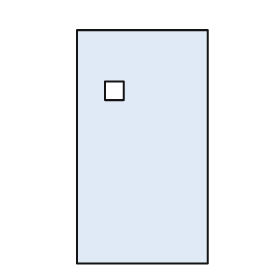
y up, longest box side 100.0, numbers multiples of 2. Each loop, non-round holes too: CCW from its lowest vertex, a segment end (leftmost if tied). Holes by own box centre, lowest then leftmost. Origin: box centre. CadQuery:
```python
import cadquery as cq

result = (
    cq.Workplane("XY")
    .moveTo(-28.0, -50.0)
    .lineTo(28.0, -50.0)
    .lineTo(28.0, 50.0)
    .lineTo(-28.0, 50.0)
    .close()
    .moveTo(-16.0, 20.0)
    .lineTo(-8.0, 20.0)
    .lineTo(-8.0, 28.0)
    .lineTo(-16.0, 28.0)
    .close()
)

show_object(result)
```